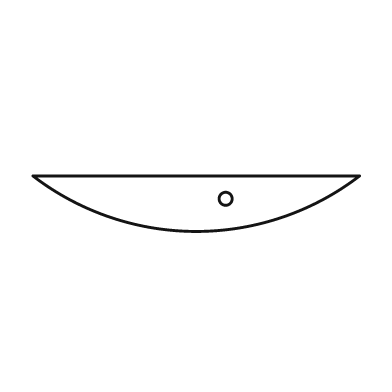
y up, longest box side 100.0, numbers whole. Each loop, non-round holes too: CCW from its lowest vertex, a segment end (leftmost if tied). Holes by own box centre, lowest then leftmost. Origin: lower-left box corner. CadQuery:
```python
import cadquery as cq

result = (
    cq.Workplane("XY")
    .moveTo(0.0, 17.0)
    .threePointArc((50.0, 0.0), (100.0, 17.0))
    .close()
    .moveTo(59.0, 10.0)
    .circle(2.0)
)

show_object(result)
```